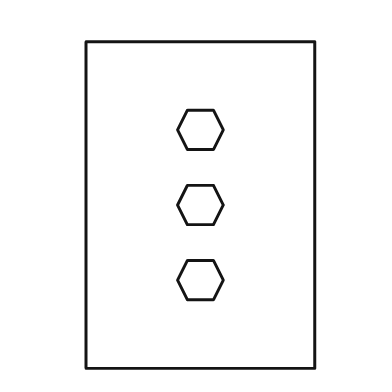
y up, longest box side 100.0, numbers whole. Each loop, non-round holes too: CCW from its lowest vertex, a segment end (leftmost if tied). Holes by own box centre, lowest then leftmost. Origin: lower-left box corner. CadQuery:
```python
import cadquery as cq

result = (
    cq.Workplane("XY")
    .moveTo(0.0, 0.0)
    .lineTo(70.0, 0.0)
    .lineTo(70.0, 100.0)
    .lineTo(0.0, 100.0)
    .close()
    .moveTo(31.0, 21.0)
    .lineTo(39.0, 21.0)
    .lineTo(42.0, 27.0)
    .lineTo(39.0, 33.0)
    .lineTo(31.0, 33.0)
    .lineTo(28.0, 27.0)
    .close()
    .moveTo(31.0, 44.0)
    .lineTo(39.0, 44.0)
    .lineTo(42.0, 50.0)
    .lineTo(39.0, 56.0)
    .lineTo(31.0, 56.0)
    .lineTo(28.0, 50.0)
    .close()
    .moveTo(31.0, 67.0)
    .lineTo(39.0, 67.0)
    .lineTo(42.0, 73.0)
    .lineTo(39.0, 79.0)
    .lineTo(31.0, 79.0)
    .lineTo(28.0, 73.0)
    .close()
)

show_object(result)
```